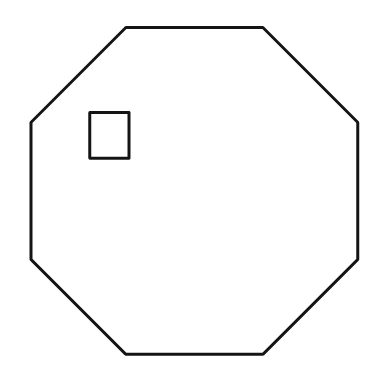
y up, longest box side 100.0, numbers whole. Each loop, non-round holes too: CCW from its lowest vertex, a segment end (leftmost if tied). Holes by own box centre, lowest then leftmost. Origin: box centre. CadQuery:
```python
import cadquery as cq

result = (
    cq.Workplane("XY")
    .moveTo(-21.0, -50.0)
    .lineTo(21.0, -50.0)
    .lineTo(50.0, -21.0)
    .lineTo(50.0, 21.0)
    .lineTo(21.0, 50.0)
    .lineTo(-21.0, 50.0)
    .lineTo(-50.0, 21.0)
    .lineTo(-50.0, -21.0)
    .close()
    .moveTo(-32.0, 10.0)
    .lineTo(-20.0, 10.0)
    .lineTo(-20.0, 24.0)
    .lineTo(-32.0, 24.0)
    .close()
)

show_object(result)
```